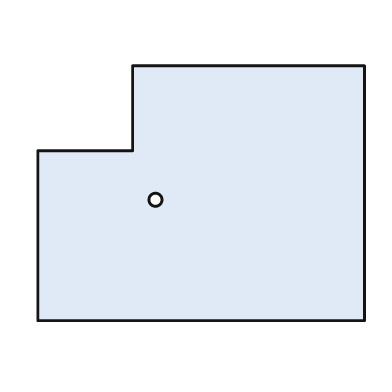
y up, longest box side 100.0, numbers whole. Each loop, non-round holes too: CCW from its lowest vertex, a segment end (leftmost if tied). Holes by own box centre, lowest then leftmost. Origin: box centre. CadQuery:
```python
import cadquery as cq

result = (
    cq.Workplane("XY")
    .moveTo(-50.0, -39.0)
    .lineTo(50.0, -39.0)
    .lineTo(50.0, 39.0)
    .lineTo(-21.0, 39.0)
    .lineTo(-21.0, 13.0)
    .lineTo(-50.0, 13.0)
    .close()
    .moveTo(-14.0, -2.0)
    .circle(2.0)
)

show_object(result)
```